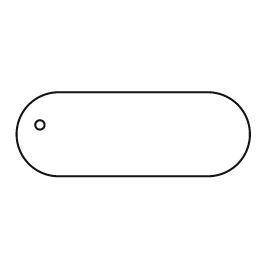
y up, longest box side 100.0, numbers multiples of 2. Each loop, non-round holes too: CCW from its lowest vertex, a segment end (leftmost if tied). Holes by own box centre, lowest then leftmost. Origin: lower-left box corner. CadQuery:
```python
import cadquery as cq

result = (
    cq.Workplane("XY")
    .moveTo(18.0, 0.0)
    .lineTo(82.0, 0.0)
    .threePointArc((100.0, 18.0), (82.0, 36.0))
    .lineTo(18.0, 36.0)
    .threePointArc((0.0, 18.0), (18.0, 0.0))
    .close()
    .moveTo(10.0, 22.0)
    .circle(2.0)
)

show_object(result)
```